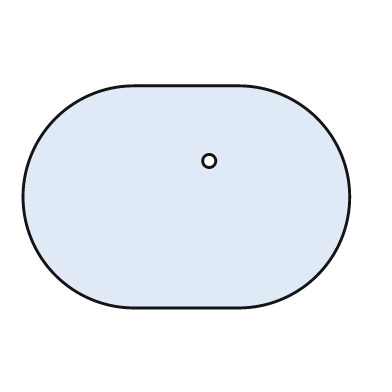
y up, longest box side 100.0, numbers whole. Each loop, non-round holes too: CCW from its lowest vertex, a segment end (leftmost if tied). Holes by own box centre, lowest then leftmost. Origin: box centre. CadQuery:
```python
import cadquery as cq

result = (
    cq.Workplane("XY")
    .moveTo(-16.0, -34.0)
    .lineTo(16.0, -34.0)
    .threePointArc((50.0, 0.0), (16.0, 34.0))
    .lineTo(-16.0, 34.0)
    .threePointArc((-50.0, 0.0), (-16.0, -34.0))
    .close()
    .moveTo(7.0, 11.0)
    .circle(2.0)
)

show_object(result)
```